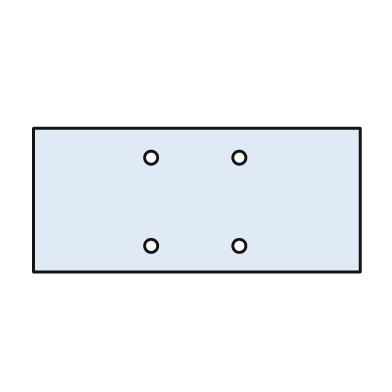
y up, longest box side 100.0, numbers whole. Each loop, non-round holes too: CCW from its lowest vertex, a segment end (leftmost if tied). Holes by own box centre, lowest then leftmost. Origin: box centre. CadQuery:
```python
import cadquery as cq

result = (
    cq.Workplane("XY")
    .moveTo(-50.0, -22.0)
    .lineTo(50.0, -22.0)
    .lineTo(50.0, 22.0)
    .lineTo(-50.0, 22.0)
    .close()
    .moveTo(-14.0, -14.0)
    .circle(2.0)
    .moveTo(13.0, -14.0)
    .circle(2.0)
    .moveTo(-14.0, 13.0)
    .circle(2.0)
    .moveTo(13.0, 13.0)
    .circle(2.0)
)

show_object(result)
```